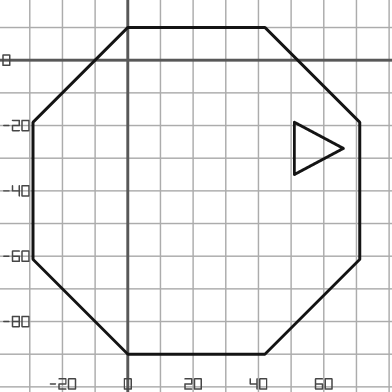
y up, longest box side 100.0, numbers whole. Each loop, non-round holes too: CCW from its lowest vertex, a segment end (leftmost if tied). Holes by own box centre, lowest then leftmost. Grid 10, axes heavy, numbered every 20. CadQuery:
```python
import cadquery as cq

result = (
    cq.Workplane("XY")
    .moveTo(0.0, -90.0)
    .lineTo(42.0, -90.0)
    .lineTo(71.0, -61.0)
    .lineTo(71.0, -19.0)
    .lineTo(42.0, 10.0)
    .lineTo(0.0, 10.0)
    .lineTo(-29.0, -19.0)
    .lineTo(-29.0, -61.0)
    .close()
    .moveTo(51.0, -35.0)
    .lineTo(66.0, -27.0)
    .lineTo(51.0, -19.0)
    .close()
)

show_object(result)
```